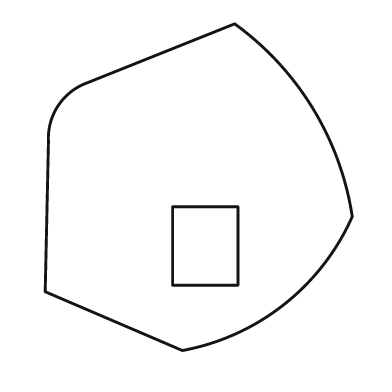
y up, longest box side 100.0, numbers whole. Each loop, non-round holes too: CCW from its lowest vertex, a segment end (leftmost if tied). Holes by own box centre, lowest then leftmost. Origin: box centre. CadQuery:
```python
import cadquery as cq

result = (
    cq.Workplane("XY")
    .moveTo(-5.0, -50.0)
    .threePointArc((26.0, -36.0), (47.0, -9.0))
    .threePointArc((35.0, 24.0), (11.0, 50.0))
    .lineTo(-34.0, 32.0)
    .threePointArc((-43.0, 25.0), (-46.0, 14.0))
    .lineTo(-47.0, -32.0)
    .close()
    .moveTo(-8.0, -30.0)
    .lineTo(12.0, -30.0)
    .lineTo(12.0, -6.0)
    .lineTo(-8.0, -6.0)
    .close()
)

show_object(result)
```